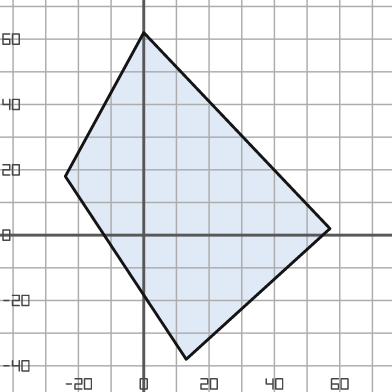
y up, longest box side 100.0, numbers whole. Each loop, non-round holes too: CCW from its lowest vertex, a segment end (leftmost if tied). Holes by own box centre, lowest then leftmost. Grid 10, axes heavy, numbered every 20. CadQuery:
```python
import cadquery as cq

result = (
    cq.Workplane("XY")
    .moveTo(13.0, -38.0)
    .lineTo(57.0, 2.0)
    .lineTo(0.0, 62.0)
    .lineTo(-24.0, 18.0)
    .close()
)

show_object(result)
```